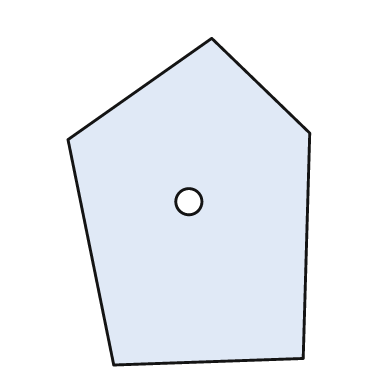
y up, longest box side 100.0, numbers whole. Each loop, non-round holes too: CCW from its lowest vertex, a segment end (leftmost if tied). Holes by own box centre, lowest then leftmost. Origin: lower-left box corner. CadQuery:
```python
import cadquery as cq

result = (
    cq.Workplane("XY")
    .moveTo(14.0, 0.0)
    .lineTo(72.0, 2.0)
    .lineTo(74.0, 71.0)
    .lineTo(44.0, 100.0)
    .lineTo(0.0, 69.0)
    .close()
    .moveTo(37.0, 50.0)
    .circle(4.0)
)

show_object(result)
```